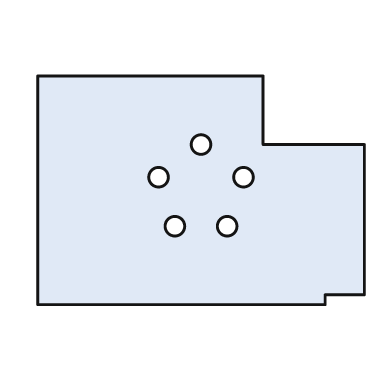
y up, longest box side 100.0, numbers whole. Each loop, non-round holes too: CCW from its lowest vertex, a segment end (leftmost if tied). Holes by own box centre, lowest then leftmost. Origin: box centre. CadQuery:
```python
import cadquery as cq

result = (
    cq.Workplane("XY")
    .moveTo(-50.0, -35.0)
    .lineTo(38.0, -35.0)
    .lineTo(38.0, -32.0)
    .lineTo(50.0, -32.0)
    .lineTo(50.0, 14.0)
    .lineTo(19.0, 14.0)
    .lineTo(19.0, 35.0)
    .lineTo(-50.0, 35.0)
    .close()
    .moveTo(-8.0, -11.0)
    .circle(3.0)
    .moveTo(8.0, -11.0)
    .circle(3.0)
    .moveTo(-13.0, 4.0)
    .circle(3.0)
    .moveTo(13.0, 4.0)
    .circle(3.0)
    .moveTo(0.0, 14.0)
    .circle(3.0)
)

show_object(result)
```